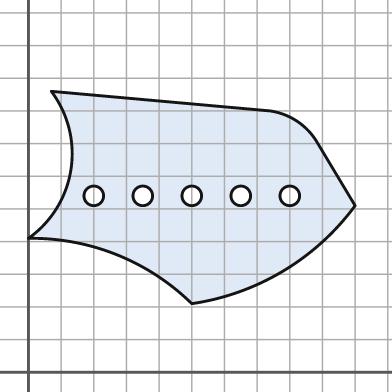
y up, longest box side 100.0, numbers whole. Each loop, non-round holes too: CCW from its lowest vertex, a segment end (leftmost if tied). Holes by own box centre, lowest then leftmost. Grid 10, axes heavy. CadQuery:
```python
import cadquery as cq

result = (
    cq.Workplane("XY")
    .moveTo(50.0, 21.0)
    .threePointArc((78.0, 31.0), (100.0, 51.0))
    .lineTo(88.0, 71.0)
    .threePointArc((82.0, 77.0), (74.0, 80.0))
    .lineTo(7.0, 86.0)
    .threePointArc((13.0, 62.0), (0.0, 41.0))
    .threePointArc((27.0, 36.0), (50.0, 21.0))
    .close()
    .moveTo(20.0, 54.0)
    .circle(3.0)
    .moveTo(35.0, 54.0)
    .circle(3.0)
    .moveTo(50.0, 54.0)
    .circle(3.0)
    .moveTo(65.0, 54.0)
    .circle(3.0)
    .moveTo(80.0, 54.0)
    .circle(3.0)
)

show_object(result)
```